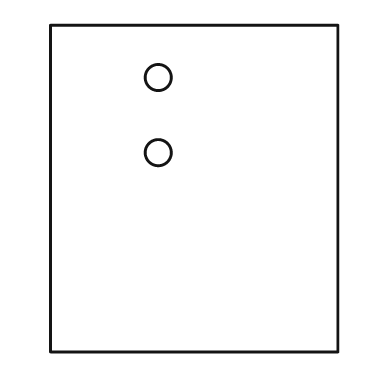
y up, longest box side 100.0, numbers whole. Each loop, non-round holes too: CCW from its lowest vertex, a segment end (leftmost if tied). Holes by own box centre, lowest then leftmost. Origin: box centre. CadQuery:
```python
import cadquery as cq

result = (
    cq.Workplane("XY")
    .moveTo(-44.0, -50.0)
    .lineTo(44.0, -50.0)
    .lineTo(44.0, 50.0)
    .lineTo(-44.0, 50.0)
    .close()
    .moveTo(-11.0, 11.0)
    .circle(4.0)
    .moveTo(-11.0, 34.0)
    .circle(4.0)
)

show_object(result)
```